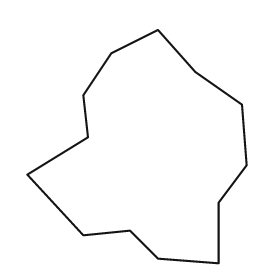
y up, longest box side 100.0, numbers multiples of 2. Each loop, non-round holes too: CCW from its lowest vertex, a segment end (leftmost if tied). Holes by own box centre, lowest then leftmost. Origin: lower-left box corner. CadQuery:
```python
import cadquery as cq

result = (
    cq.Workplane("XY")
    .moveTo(82.0, 0.0)
    .lineTo(82.0, 26.0)
    .lineTo(94.0, 42.0)
    .lineTo(92.0, 68.0)
    .lineTo(72.0, 82.0)
    .lineTo(56.0, 100.0)
    .lineTo(36.0, 90.0)
    .lineTo(24.0, 72.0)
    .lineTo(26.0, 54.0)
    .lineTo(0.0, 38.0)
    .lineTo(24.0, 12.0)
    .lineTo(44.0, 14.0)
    .lineTo(56.0, 2.0)
    .close()
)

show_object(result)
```